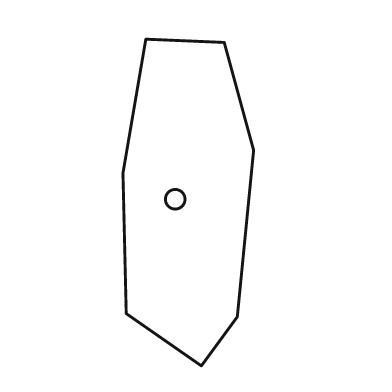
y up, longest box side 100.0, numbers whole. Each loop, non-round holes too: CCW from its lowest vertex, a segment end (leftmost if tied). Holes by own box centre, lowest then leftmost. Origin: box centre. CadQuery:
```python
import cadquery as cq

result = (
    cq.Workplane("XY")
    .moveTo(4.0, -50.0)
    .lineTo(15.0, -35.0)
    .lineTo(20.0, 16.0)
    .lineTo(11.0, 49.0)
    .lineTo(-13.0, 50.0)
    .lineTo(-20.0, 9.0)
    .lineTo(-19.0, -34.0)
    .close()
    .moveTo(-4.0, 1.0)
    .circle(3.0)
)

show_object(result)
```